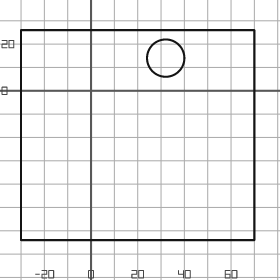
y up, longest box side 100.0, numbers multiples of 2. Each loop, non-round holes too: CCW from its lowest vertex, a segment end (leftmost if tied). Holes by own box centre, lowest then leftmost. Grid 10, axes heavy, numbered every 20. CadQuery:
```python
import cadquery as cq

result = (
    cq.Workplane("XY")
    .moveTo(-30.0, -64.0)
    .lineTo(70.0, -64.0)
    .lineTo(70.0, 26.0)
    .lineTo(-30.0, 26.0)
    .close()
    .moveTo(32.0, 14.0)
    .circle(8.0)
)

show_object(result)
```